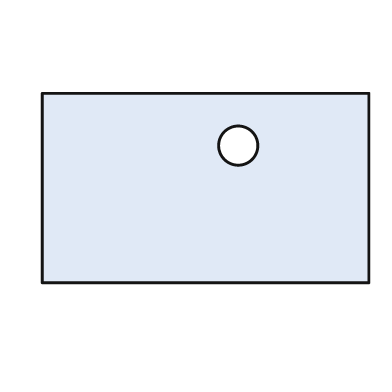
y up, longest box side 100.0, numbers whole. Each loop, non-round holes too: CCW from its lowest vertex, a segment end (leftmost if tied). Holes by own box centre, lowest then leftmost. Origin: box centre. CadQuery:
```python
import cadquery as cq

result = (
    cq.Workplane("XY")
    .moveTo(-50.0, -29.0)
    .lineTo(50.0, -29.0)
    .lineTo(50.0, 29.0)
    .lineTo(-50.0, 29.0)
    .close()
    .moveTo(10.0, 13.0)
    .circle(6.0)
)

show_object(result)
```